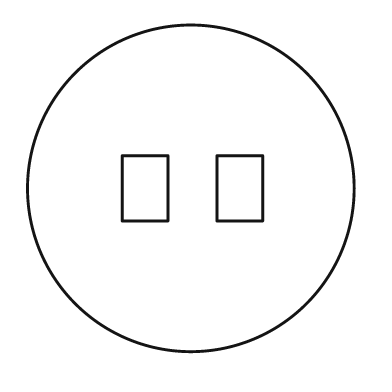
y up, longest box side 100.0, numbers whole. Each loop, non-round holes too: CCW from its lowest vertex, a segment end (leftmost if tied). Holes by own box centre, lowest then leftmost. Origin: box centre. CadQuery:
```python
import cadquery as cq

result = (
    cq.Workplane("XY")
    .moveTo(0.0, 0.0)
    .circle(50.0)
    .moveTo(-21.0, -10.0)
    .lineTo(-7.0, -10.0)
    .lineTo(-7.0, 10.0)
    .lineTo(-21.0, 10.0)
    .close()
    .moveTo(8.0, -10.0)
    .lineTo(22.0, -10.0)
    .lineTo(22.0, 10.0)
    .lineTo(8.0, 10.0)
    .close()
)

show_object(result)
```